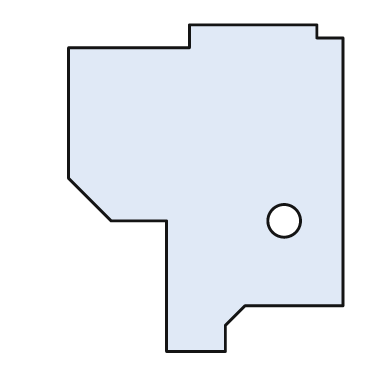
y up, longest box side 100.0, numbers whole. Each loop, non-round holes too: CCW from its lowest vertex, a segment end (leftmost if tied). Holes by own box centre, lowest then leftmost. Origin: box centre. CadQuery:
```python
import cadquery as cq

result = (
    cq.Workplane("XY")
    .moveTo(-12.0, -50.0)
    .lineTo(6.0, -50.0)
    .lineTo(6.0, -42.0)
    .lineTo(12.0, -36.0)
    .lineTo(42.0, -36.0)
    .lineTo(42.0, 46.0)
    .lineTo(34.0, 46.0)
    .lineTo(34.0, 50.0)
    .lineTo(-5.0, 50.0)
    .lineTo(-5.0, 43.0)
    .lineTo(-42.0, 43.0)
    .lineTo(-42.0, 3.0)
    .lineTo(-29.0, -10.0)
    .lineTo(-12.0, -10.0)
    .close()
    .moveTo(24.0, -10.0)
    .circle(5.0)
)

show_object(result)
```